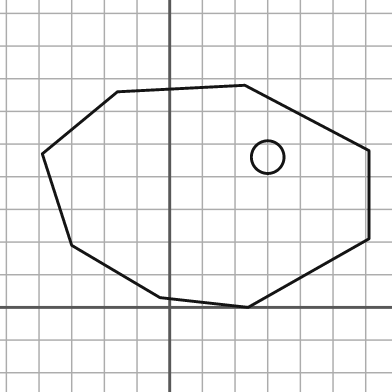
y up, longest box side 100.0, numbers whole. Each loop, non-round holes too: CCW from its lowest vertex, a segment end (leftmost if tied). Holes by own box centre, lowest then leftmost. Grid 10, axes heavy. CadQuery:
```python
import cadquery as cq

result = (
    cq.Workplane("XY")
    .moveTo(24.0, 0.0)
    .lineTo(61.0, 21.0)
    .lineTo(61.0, 48.0)
    .lineTo(23.0, 68.0)
    .lineTo(-16.0, 66.0)
    .lineTo(-39.0, 47.0)
    .lineTo(-30.0, 19.0)
    .lineTo(-3.0, 3.0)
    .close()
    .moveTo(30.0, 46.0)
    .circle(5.0)
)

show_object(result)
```